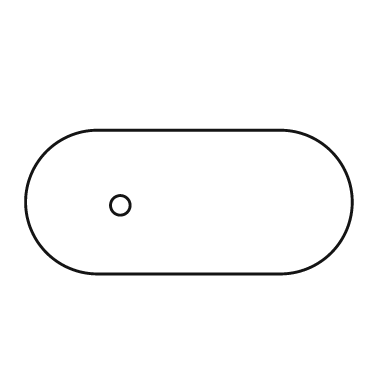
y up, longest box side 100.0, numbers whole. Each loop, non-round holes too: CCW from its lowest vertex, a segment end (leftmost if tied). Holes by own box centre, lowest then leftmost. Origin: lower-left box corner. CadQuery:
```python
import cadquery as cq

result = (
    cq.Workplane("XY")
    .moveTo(22.0, 0.0)
    .lineTo(78.0, 0.0)
    .threePointArc((100.0, 22.0), (78.0, 44.0))
    .lineTo(22.0, 44.0)
    .threePointArc((0.0, 22.0), (22.0, 0.0))
    .close()
    .moveTo(29.0, 21.0)
    .circle(3.0)
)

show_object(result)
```